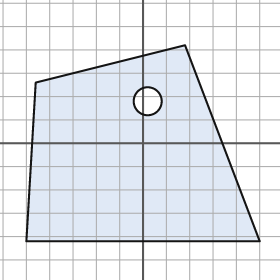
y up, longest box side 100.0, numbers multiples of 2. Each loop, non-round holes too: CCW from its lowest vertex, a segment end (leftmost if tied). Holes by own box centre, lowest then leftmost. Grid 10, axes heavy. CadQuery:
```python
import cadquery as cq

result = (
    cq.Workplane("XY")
    .moveTo(-50.0, -42.0)
    .lineTo(50.0, -42.0)
    .lineTo(18.0, 42.0)
    .lineTo(-46.0, 26.0)
    .close()
    .moveTo(2.0, 18.0)
    .circle(6.0)
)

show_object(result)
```